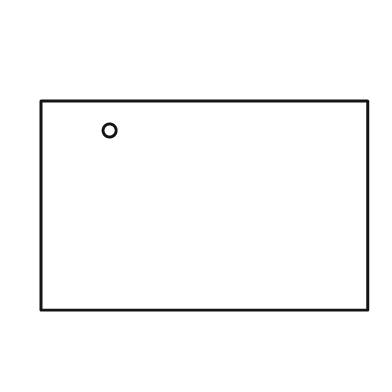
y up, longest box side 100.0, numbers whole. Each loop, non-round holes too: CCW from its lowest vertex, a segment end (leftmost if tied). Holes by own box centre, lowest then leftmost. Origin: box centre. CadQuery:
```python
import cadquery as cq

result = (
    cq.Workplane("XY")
    .moveTo(-50.0, -32.0)
    .lineTo(50.0, -32.0)
    .lineTo(50.0, 32.0)
    .lineTo(-50.0, 32.0)
    .close()
    .moveTo(-29.0, 23.0)
    .circle(2.0)
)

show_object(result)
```